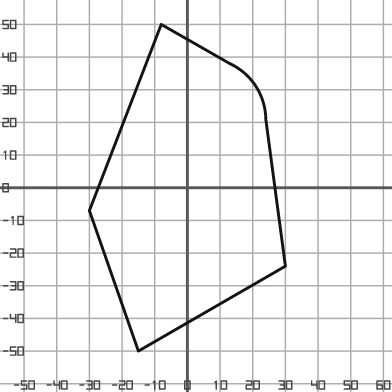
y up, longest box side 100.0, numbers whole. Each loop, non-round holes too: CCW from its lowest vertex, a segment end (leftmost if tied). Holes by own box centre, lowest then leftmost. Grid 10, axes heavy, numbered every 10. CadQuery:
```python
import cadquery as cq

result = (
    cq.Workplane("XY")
    .moveTo(-15.0, -50.0)
    .lineTo(30.0, -24.0)
    .lineTo(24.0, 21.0)
    .threePointArc((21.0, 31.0), (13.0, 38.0))
    .lineTo(-8.0, 50.0)
    .lineTo(-30.0, -7.0)
    .close()
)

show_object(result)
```